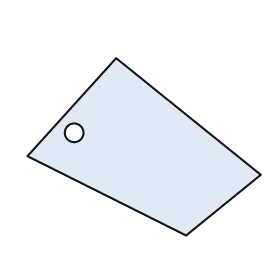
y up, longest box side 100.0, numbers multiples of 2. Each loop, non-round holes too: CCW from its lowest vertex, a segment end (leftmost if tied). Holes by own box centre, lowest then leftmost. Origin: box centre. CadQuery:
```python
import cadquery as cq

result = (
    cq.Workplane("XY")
    .moveTo(18.0, -38.0)
    .lineTo(50.0, -12.0)
    .lineTo(-12.0, 38.0)
    .lineTo(-50.0, -4.0)
    .close()
    .moveTo(-30.0, 6.0)
    .circle(4.0)
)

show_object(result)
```